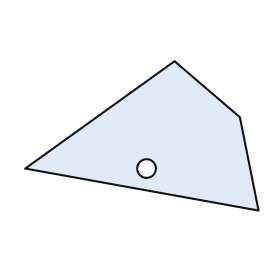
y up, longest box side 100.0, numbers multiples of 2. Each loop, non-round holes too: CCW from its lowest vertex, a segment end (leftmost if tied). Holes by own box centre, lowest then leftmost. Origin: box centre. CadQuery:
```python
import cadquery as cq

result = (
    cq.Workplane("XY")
    .moveTo(50.0, -32.0)
    .lineTo(42.0, 8.0)
    .lineTo(14.0, 32.0)
    .lineTo(-50.0, -14.0)
    .close()
    .moveTo(2.0, -14.0)
    .circle(4.0)
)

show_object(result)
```